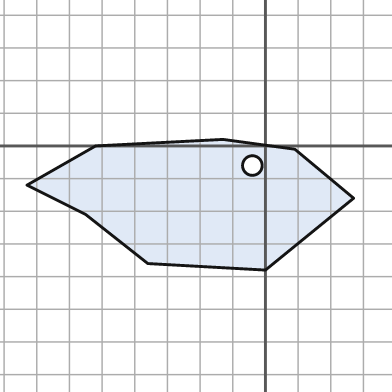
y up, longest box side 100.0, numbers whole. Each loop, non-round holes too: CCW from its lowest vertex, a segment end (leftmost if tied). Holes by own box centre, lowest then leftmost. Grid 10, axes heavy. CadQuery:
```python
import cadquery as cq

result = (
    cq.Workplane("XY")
    .moveTo(0.0, -38.0)
    .lineTo(27.0, -16.0)
    .lineTo(9.0, -1.0)
    .lineTo(-13.0, 2.0)
    .lineTo(-52.0, 0.0)
    .lineTo(-73.0, -12.0)
    .lineTo(-55.0, -21.0)
    .lineTo(-36.0, -36.0)
    .close()
    .moveTo(-4.0, -6.0)
    .circle(3.0)
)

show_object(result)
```